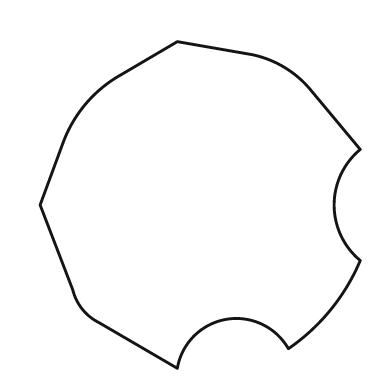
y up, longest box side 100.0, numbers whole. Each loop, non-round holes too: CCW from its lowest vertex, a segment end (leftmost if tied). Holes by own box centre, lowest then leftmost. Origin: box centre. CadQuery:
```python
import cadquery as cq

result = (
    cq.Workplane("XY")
    .moveTo(-7.0, -50.0)
    .threePointArc((8.0, -35.0), (27.0, -44.0))
    .threePointArc((40.0, -32.0), (49.0, -17.0))
    .threePointArc((41.0, 0.0), (49.0, 17.0))
    .lineTo(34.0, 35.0)
    .threePointArc((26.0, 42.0), (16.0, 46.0))
    .lineTo(-7.0, 50.0)
    .lineTo(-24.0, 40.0)
    .threePointArc((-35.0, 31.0), (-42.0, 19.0))
    .lineTo(-49.0, 0.0)
    .lineTo(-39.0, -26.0)
    .threePointArc((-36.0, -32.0), (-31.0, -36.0))
    .close()
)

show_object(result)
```